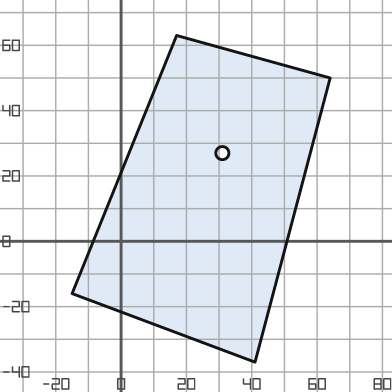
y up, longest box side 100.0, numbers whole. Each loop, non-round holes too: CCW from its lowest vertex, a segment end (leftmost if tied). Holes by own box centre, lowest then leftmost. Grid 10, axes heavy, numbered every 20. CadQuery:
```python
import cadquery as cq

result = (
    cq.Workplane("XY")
    .moveTo(41.0, -37.0)
    .lineTo(64.0, 50.0)
    .lineTo(17.0, 63.0)
    .lineTo(-15.0, -16.0)
    .close()
    .moveTo(31.0, 27.0)
    .circle(2.0)
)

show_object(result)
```